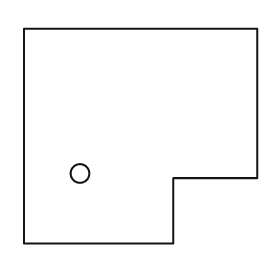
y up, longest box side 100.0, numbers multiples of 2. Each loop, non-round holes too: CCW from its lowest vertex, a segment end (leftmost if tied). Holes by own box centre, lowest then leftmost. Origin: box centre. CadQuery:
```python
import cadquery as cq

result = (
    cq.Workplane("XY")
    .moveTo(-50.0, -46.0)
    .lineTo(14.0, -46.0)
    .lineTo(14.0, -18.0)
    .lineTo(50.0, -18.0)
    .lineTo(50.0, 46.0)
    .lineTo(-50.0, 46.0)
    .close()
    .moveTo(-26.0, -16.0)
    .circle(4.0)
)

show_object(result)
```